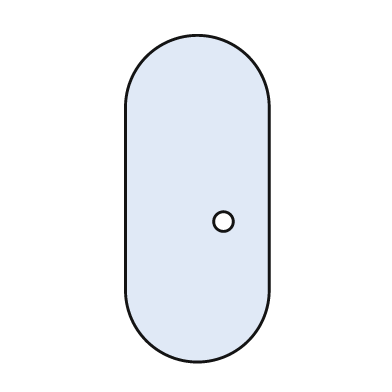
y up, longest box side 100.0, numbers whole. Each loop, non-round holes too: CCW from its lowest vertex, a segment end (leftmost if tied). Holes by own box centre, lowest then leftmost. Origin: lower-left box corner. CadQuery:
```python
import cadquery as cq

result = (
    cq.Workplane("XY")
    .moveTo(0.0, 22.0)
    .threePointArc((22.0, 0.0), (44.0, 22.0))
    .lineTo(44.0, 78.0)
    .threePointArc((22.0, 100.0), (0.0, 78.0))
    .close()
    .moveTo(30.0, 43.0)
    .circle(3.0)
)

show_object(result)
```